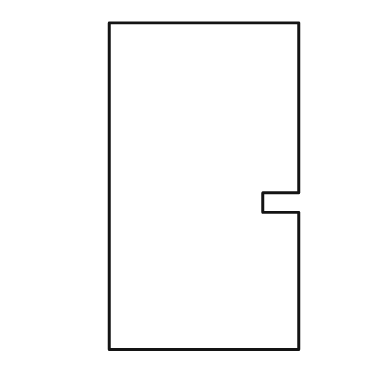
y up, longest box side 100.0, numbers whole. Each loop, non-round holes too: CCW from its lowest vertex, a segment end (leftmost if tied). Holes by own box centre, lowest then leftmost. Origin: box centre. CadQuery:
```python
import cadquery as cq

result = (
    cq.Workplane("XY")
    .moveTo(-29.0, -50.0)
    .lineTo(29.0, -50.0)
    .lineTo(29.0, -8.0)
    .lineTo(18.0, -8.0)
    .lineTo(18.0, -2.0)
    .lineTo(29.0, -2.0)
    .lineTo(29.0, 50.0)
    .lineTo(-29.0, 50.0)
    .close()
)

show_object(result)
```